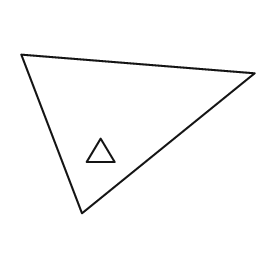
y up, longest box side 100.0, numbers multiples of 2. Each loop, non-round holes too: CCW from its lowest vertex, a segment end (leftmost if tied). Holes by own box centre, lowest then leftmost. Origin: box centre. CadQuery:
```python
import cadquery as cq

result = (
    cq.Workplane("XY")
    .moveTo(-24.0, -34.0)
    .lineTo(50.0, 26.0)
    .lineTo(-50.0, 34.0)
    .close()
    .moveTo(-22.0, -12.0)
    .lineTo(-10.0, -12.0)
    .lineTo(-16.0, -2.0)
    .close()
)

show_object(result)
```